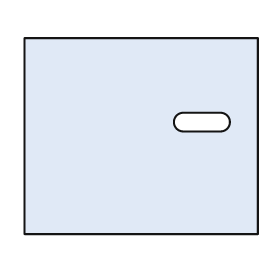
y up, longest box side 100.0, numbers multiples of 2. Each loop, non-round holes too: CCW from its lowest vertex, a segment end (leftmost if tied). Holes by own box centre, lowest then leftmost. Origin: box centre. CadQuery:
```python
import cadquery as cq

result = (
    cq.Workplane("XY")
    .moveTo(-50.0, -42.0)
    .lineTo(50.0, -42.0)
    .lineTo(50.0, 42.0)
    .lineTo(-50.0, 42.0)
    .close()
    .moveTo(18.0, 2.0)
    .lineTo(34.0, 2.0)
    .threePointArc((38.0, 6.0), (34.0, 10.0))
    .lineTo(18.0, 10.0)
    .threePointArc((14.0, 6.0), (18.0, 2.0))
    .close()
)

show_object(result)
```